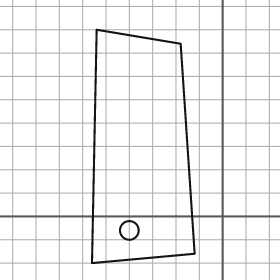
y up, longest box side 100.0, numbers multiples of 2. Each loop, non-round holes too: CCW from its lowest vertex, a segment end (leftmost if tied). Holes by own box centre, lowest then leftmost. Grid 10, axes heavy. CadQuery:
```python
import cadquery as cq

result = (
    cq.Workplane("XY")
    .moveTo(-56.0, -20.0)
    .lineTo(-12.0, -16.0)
    .lineTo(-18.0, 74.0)
    .lineTo(-54.0, 80.0)
    .close()
    .moveTo(-40.0, -6.0)
    .circle(4.0)
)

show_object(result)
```